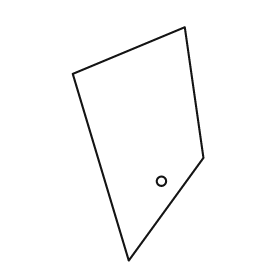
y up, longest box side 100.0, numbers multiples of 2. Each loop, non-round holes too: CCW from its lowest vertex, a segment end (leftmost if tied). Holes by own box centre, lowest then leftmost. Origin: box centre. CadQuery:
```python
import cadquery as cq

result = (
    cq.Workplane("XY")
    .moveTo(-4.0, -50.0)
    .lineTo(28.0, -6.0)
    .lineTo(20.0, 50.0)
    .lineTo(-28.0, 30.0)
    .close()
    .moveTo(10.0, -16.0)
    .circle(2.0)
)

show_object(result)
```